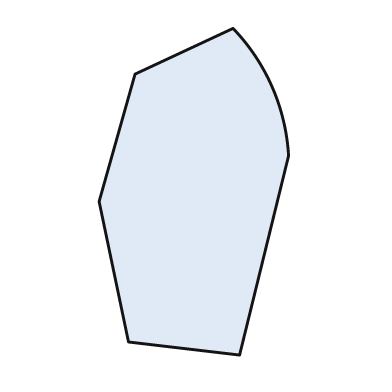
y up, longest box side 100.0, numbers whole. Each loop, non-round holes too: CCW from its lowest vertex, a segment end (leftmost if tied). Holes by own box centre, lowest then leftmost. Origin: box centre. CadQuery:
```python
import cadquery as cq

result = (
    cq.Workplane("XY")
    .moveTo(14.0, -50.0)
    .lineTo(29.0, 11.0)
    .threePointArc((24.0, 32.0), (12.0, 50.0))
    .lineTo(-18.0, 36.0)
    .lineTo(-29.0, -3.0)
    .lineTo(-20.0, -46.0)
    .close()
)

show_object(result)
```